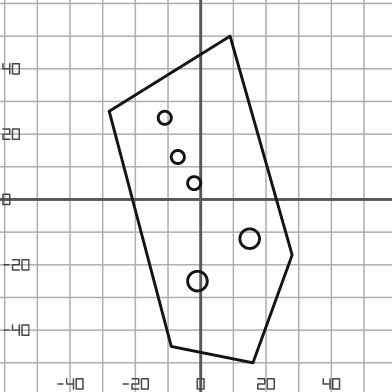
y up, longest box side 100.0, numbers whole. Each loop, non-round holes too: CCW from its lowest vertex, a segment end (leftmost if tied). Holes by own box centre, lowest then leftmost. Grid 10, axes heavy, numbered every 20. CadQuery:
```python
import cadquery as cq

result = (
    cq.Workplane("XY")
    .moveTo(16.0, -50.0)
    .lineTo(28.0, -17.0)
    .lineTo(9.0, 50.0)
    .lineTo(-28.0, 27.0)
    .lineTo(-9.0, -45.0)
    .close()
    .moveTo(-1.0, -25.0)
    .circle(3.0)
    .moveTo(15.0, -12.0)
    .circle(3.0)
    .moveTo(-2.0, 5.0)
    .circle(2.0)
    .moveTo(-7.0, 13.0)
    .circle(2.0)
    .moveTo(-11.0, 25.0)
    .circle(2.0)
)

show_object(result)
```